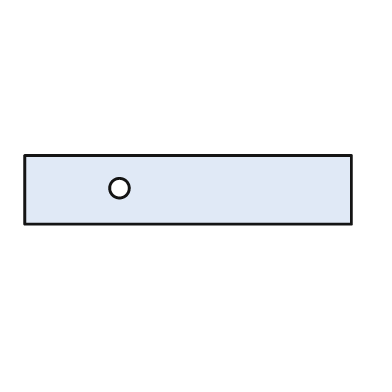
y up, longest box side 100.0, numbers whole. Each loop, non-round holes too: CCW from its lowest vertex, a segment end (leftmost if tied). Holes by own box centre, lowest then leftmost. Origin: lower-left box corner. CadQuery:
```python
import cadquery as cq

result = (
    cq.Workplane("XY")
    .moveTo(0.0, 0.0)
    .lineTo(100.0, 0.0)
    .lineTo(100.0, 21.0)
    .lineTo(0.0, 21.0)
    .close()
    .moveTo(29.0, 11.0)
    .circle(3.0)
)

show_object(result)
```